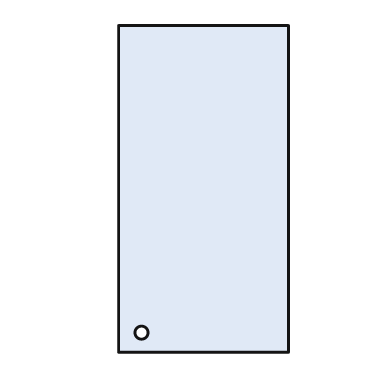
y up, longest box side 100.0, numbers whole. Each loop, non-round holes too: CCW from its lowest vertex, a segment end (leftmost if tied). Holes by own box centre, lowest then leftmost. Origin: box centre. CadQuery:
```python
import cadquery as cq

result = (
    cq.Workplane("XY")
    .moveTo(-26.0, -50.0)
    .lineTo(26.0, -50.0)
    .lineTo(26.0, 50.0)
    .lineTo(-26.0, 50.0)
    .close()
    .moveTo(-19.0, -44.0)
    .circle(2.0)
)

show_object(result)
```